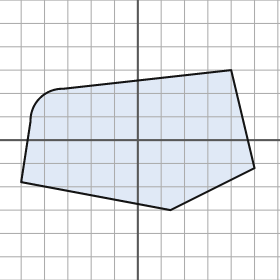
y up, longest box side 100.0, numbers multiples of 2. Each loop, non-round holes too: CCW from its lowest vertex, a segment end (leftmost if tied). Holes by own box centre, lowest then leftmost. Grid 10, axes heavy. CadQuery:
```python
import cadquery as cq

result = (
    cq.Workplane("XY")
    .moveTo(14.0, -30.0)
    .lineTo(50.0, -12.0)
    .lineTo(40.0, 30.0)
    .lineTo(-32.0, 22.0)
    .threePointArc((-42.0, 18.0), (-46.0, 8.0))
    .lineTo(-50.0, -18.0)
    .close()
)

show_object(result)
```